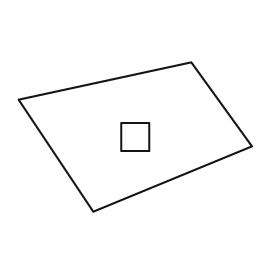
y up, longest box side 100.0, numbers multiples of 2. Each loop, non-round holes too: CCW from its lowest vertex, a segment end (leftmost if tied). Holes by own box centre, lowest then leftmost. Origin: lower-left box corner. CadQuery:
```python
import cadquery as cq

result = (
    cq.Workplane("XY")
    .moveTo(32.0, 0.0)
    .lineTo(100.0, 28.0)
    .lineTo(74.0, 64.0)
    .lineTo(0.0, 48.0)
    .close()
    .moveTo(44.0, 26.0)
    .lineTo(56.0, 26.0)
    .lineTo(56.0, 38.0)
    .lineTo(44.0, 38.0)
    .close()
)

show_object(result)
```